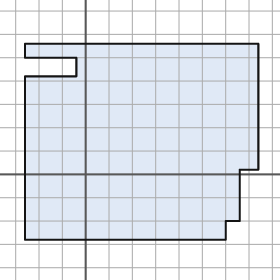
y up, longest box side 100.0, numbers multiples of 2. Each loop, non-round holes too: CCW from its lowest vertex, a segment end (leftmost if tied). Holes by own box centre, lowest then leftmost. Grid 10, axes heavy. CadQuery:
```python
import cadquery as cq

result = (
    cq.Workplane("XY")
    .moveTo(-26.0, -28.0)
    .lineTo(60.0, -28.0)
    .lineTo(60.0, -20.0)
    .lineTo(66.0, -20.0)
    .lineTo(66.0, 2.0)
    .lineTo(74.0, 2.0)
    .lineTo(74.0, 56.0)
    .lineTo(-26.0, 56.0)
    .lineTo(-26.0, 50.0)
    .lineTo(-4.0, 50.0)
    .lineTo(-4.0, 42.0)
    .lineTo(-26.0, 42.0)
    .close()
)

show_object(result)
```